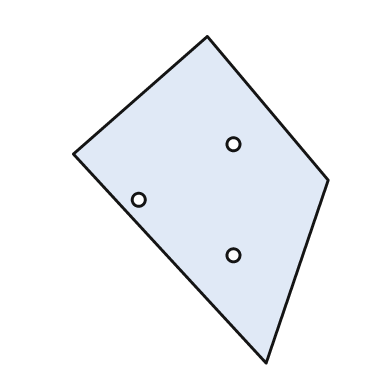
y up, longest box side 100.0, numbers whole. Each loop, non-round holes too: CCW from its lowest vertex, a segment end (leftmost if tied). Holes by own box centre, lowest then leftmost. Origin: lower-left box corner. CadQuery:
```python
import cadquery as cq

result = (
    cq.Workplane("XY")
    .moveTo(59.0, 0.0)
    .lineTo(78.0, 56.0)
    .lineTo(41.0, 100.0)
    .lineTo(0.0, 64.0)
    .close()
    .moveTo(49.0, 33.0)
    .circle(2.0)
    .moveTo(20.0, 50.0)
    .circle(2.0)
    .moveTo(49.0, 67.0)
    .circle(2.0)
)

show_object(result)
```